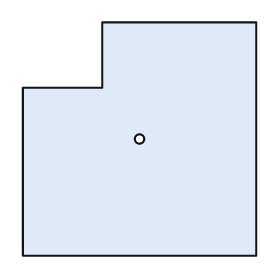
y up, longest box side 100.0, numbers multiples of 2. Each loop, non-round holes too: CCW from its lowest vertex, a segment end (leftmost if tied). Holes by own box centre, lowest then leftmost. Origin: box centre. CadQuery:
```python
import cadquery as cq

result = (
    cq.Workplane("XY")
    .moveTo(-50.0, -50.0)
    .lineTo(50.0, -50.0)
    .lineTo(50.0, 50.0)
    .lineTo(-16.0, 50.0)
    .lineTo(-16.0, 22.0)
    .lineTo(-50.0, 22.0)
    .close()
    .moveTo(0.0, 0.0)
    .circle(2.0)
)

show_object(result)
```